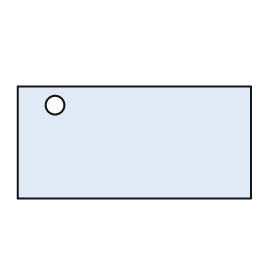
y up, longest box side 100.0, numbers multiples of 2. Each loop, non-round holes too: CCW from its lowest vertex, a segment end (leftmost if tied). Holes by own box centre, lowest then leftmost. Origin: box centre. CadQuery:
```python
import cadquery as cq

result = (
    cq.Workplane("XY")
    .moveTo(-50.0, -24.0)
    .lineTo(50.0, -24.0)
    .lineTo(50.0, 24.0)
    .lineTo(-50.0, 24.0)
    .close()
    .moveTo(-34.0, 16.0)
    .circle(4.0)
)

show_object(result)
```